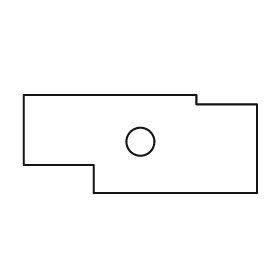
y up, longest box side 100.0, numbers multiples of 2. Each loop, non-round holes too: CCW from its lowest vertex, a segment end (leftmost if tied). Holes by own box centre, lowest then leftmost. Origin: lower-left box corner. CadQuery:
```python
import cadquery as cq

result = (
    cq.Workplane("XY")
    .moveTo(30.0, 0.0)
    .lineTo(100.0, 0.0)
    .lineTo(100.0, 38.0)
    .lineTo(74.0, 38.0)
    .lineTo(74.0, 42.0)
    .lineTo(0.0, 42.0)
    .lineTo(0.0, 12.0)
    .lineTo(30.0, 12.0)
    .close()
    .moveTo(50.0, 22.0)
    .circle(6.0)
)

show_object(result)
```